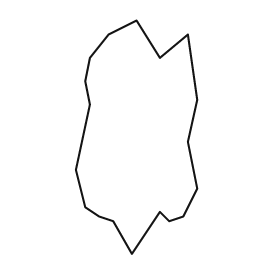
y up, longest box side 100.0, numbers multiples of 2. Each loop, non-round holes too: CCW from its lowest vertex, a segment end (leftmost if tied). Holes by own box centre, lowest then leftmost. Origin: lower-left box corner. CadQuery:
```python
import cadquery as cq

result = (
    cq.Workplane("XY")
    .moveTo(24.0, 0.0)
    .lineTo(36.0, 18.0)
    .lineTo(40.0, 14.0)
    .lineTo(46.0, 16.0)
    .lineTo(52.0, 28.0)
    .lineTo(48.0, 48.0)
    .lineTo(52.0, 66.0)
    .lineTo(48.0, 94.0)
    .lineTo(36.0, 84.0)
    .lineTo(26.0, 100.0)
    .lineTo(14.0, 94.0)
    .lineTo(6.0, 84.0)
    .lineTo(4.0, 74.0)
    .lineTo(6.0, 64.0)
    .lineTo(0.0, 36.0)
    .lineTo(4.0, 20.0)
    .lineTo(10.0, 16.0)
    .lineTo(16.0, 14.0)
    .close()
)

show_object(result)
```